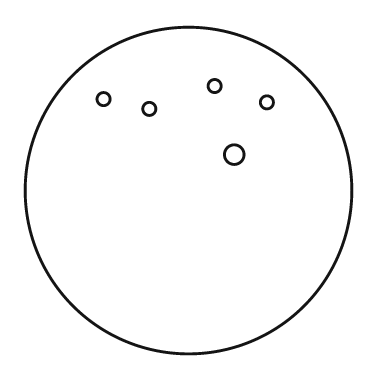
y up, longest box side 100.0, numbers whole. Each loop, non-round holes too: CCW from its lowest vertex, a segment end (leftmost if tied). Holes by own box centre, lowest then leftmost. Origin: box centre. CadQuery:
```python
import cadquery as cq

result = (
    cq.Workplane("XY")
    .moveTo(0.0, 0.0)
    .circle(50.0)
    .moveTo(14.0, 11.0)
    .circle(3.0)
    .moveTo(-12.0, 25.0)
    .circle(2.0)
    .moveTo(24.0, 27.0)
    .circle(2.0)
    .moveTo(-26.0, 28.0)
    .circle(2.0)
    .moveTo(8.0, 32.0)
    .circle(2.0)
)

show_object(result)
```